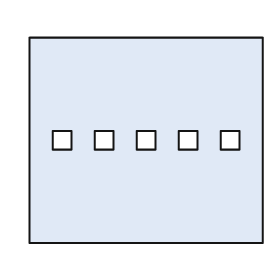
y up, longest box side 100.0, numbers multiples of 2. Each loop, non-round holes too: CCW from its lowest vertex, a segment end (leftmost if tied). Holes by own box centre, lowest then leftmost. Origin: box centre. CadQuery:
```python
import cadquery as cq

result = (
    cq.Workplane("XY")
    .moveTo(-50.0, -44.0)
    .lineTo(50.0, -44.0)
    .lineTo(50.0, 44.0)
    .lineTo(-50.0, 44.0)
    .close()
    .moveTo(-40.0, -4.0)
    .lineTo(-32.0, -4.0)
    .lineTo(-32.0, 4.0)
    .lineTo(-40.0, 4.0)
    .close()
    .moveTo(-22.0, -4.0)
    .lineTo(-14.0, -4.0)
    .lineTo(-14.0, 4.0)
    .lineTo(-22.0, 4.0)
    .close()
    .moveTo(-4.0, -4.0)
    .lineTo(4.0, -4.0)
    .lineTo(4.0, 4.0)
    .lineTo(-4.0, 4.0)
    .close()
    .moveTo(14.0, -4.0)
    .lineTo(22.0, -4.0)
    .lineTo(22.0, 4.0)
    .lineTo(14.0, 4.0)
    .close()
    .moveTo(32.0, -4.0)
    .lineTo(40.0, -4.0)
    .lineTo(40.0, 4.0)
    .lineTo(32.0, 4.0)
    .close()
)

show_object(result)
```